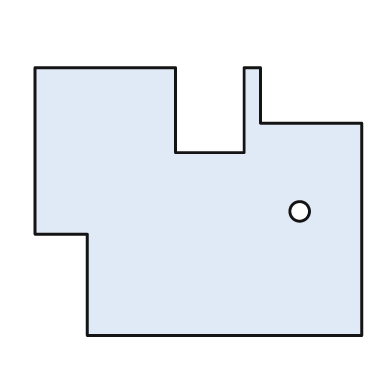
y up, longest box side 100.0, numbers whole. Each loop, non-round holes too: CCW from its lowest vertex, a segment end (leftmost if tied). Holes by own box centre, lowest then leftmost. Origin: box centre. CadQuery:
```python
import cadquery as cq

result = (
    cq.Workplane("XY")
    .moveTo(-34.0, -41.0)
    .lineTo(50.0, -41.0)
    .lineTo(50.0, 24.0)
    .lineTo(19.0, 24.0)
    .lineTo(19.0, 41.0)
    .lineTo(14.0, 41.0)
    .lineTo(14.0, 15.0)
    .lineTo(-7.0, 15.0)
    .lineTo(-7.0, 41.0)
    .lineTo(-50.0, 41.0)
    .lineTo(-50.0, -10.0)
    .lineTo(-34.0, -10.0)
    .close()
    .moveTo(31.0, -3.0)
    .circle(3.0)
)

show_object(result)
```